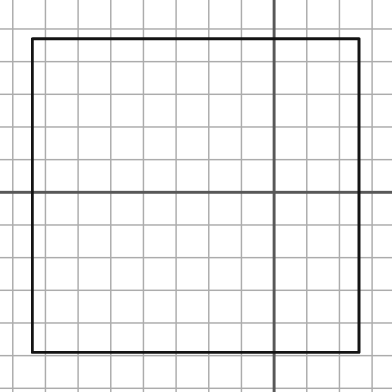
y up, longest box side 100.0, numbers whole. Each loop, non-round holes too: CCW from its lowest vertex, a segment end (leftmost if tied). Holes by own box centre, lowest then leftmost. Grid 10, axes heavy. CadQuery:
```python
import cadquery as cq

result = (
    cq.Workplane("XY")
    .moveTo(-74.0, -49.0)
    .lineTo(26.0, -49.0)
    .lineTo(26.0, 47.0)
    .lineTo(-74.0, 47.0)
    .close()
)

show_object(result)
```